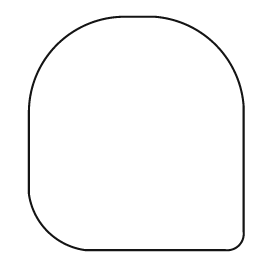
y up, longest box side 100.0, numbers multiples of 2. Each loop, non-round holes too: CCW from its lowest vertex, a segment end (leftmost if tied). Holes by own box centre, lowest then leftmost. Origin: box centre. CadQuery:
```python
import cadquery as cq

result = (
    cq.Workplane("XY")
    .moveTo(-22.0, -50.0)
    .lineTo(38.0, -50.0)
    .threePointArc((44.0, -48.0), (46.0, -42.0))
    .lineTo(46.0, 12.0)
    .threePointArc((34.0, 38.0), (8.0, 50.0))
    .lineTo(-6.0, 50.0)
    .threePointArc((-34.0, 38.0), (-46.0, 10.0))
    .lineTo(-46.0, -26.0)
    .threePointArc((-38.0, -42.0), (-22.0, -50.0))
    .close()
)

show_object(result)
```